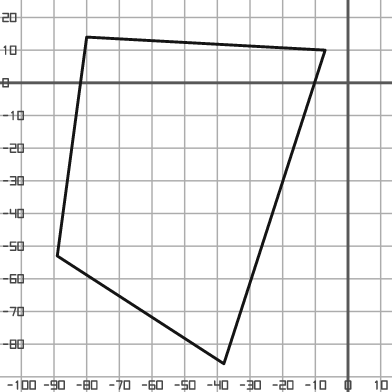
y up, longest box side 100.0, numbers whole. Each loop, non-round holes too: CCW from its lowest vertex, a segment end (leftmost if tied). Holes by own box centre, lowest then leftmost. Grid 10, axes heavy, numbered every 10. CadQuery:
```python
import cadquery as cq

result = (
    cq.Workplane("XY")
    .moveTo(-38.0, -86.0)
    .lineTo(-7.0, 10.0)
    .lineTo(-80.0, 14.0)
    .lineTo(-89.0, -53.0)
    .close()
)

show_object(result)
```